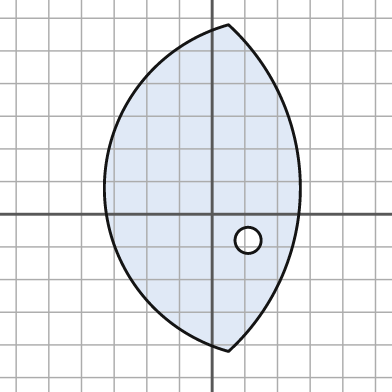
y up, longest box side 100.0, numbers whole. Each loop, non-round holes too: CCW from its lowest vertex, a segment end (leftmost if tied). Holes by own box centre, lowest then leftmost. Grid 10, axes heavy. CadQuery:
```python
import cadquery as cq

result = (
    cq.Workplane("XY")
    .moveTo(5.0, -42.0)
    .threePointArc((27.0, 8.0), (5.0, 58.0))
    .threePointArc((-33.0, 8.0), (5.0, -42.0))
    .close()
    .moveTo(11.0, -8.0)
    .circle(4.0)
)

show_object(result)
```